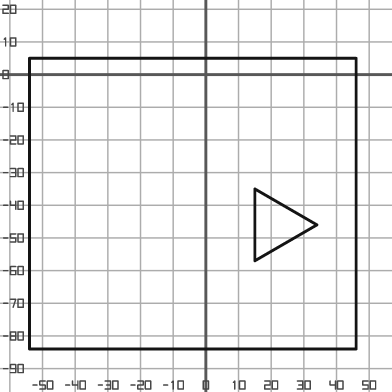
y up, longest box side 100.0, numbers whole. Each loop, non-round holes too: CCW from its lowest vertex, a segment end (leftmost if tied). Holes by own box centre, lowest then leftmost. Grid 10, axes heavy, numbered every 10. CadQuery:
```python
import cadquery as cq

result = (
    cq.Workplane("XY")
    .moveTo(-54.0, -84.0)
    .lineTo(46.0, -84.0)
    .lineTo(46.0, 5.0)
    .lineTo(-54.0, 5.0)
    .close()
    .moveTo(15.0, -57.0)
    .lineTo(34.0, -46.0)
    .lineTo(15.0, -35.0)
    .close()
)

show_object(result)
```